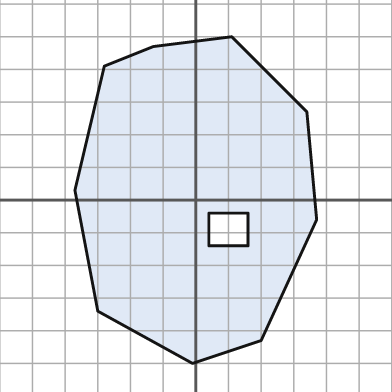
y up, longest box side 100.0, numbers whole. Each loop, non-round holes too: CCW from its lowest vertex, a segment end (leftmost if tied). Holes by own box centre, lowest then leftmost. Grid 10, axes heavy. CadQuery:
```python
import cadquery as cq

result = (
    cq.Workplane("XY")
    .moveTo(-1.0, -50.0)
    .lineTo(20.0, -43.0)
    .lineTo(37.0, -6.0)
    .lineTo(34.0, 27.0)
    .lineTo(11.0, 50.0)
    .lineTo(-13.0, 47.0)
    .lineTo(-28.0, 41.0)
    .lineTo(-37.0, 3.0)
    .lineTo(-30.0, -34.0)
    .close()
    .moveTo(4.0, -14.0)
    .lineTo(16.0, -14.0)
    .lineTo(16.0, -4.0)
    .lineTo(4.0, -4.0)
    .close()
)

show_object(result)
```